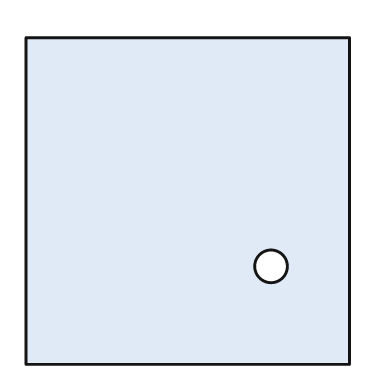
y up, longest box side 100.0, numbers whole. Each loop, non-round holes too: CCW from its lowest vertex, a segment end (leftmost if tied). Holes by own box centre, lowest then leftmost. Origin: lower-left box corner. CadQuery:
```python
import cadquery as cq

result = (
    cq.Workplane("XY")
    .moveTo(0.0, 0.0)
    .lineTo(99.0, 0.0)
    .lineTo(99.0, 100.0)
    .lineTo(0.0, 100.0)
    .close()
    .moveTo(75.0, 30.0)
    .circle(5.0)
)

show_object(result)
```